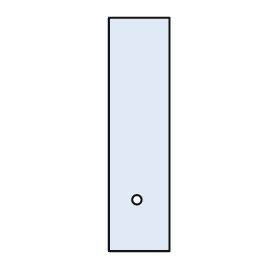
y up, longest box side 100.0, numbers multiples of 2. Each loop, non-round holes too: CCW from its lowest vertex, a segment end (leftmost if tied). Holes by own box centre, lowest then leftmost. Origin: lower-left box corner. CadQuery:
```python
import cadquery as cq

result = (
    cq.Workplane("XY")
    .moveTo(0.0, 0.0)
    .lineTo(26.0, 0.0)
    .lineTo(26.0, 100.0)
    .lineTo(0.0, 100.0)
    .close()
    .moveTo(12.0, 22.0)
    .circle(2.0)
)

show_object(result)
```